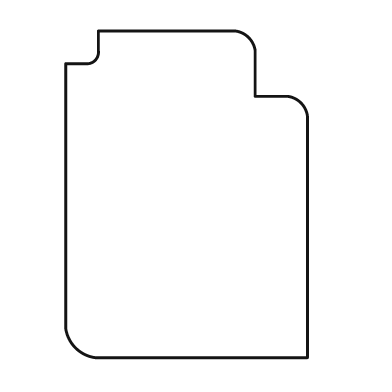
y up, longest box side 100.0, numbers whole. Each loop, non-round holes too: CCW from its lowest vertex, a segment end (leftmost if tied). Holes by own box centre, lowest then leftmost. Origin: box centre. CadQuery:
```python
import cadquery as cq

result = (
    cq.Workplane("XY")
    .moveTo(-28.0, -50.0)
    .lineTo(37.0, -50.0)
    .lineTo(37.0, 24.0)
    .threePointArc((35.0, 28.0), (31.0, 30.0))
    .lineTo(21.0, 30.0)
    .lineTo(21.0, 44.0)
    .threePointArc((19.0, 48.0), (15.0, 50.0))
    .lineTo(-27.0, 50.0)
    .lineTo(-27.0, 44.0)
    .threePointArc((-28.0, 41.0), (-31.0, 40.0))
    .lineTo(-37.0, 40.0)
    .lineTo(-37.0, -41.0)
    .threePointArc((-34.0, -47.0), (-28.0, -50.0))
    .close()
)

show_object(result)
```